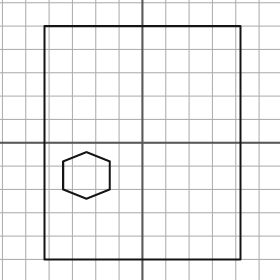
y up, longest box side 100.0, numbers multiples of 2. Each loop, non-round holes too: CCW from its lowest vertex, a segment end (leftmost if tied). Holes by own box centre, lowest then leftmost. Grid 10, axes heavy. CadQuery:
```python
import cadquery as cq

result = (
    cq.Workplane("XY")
    .moveTo(-42.0, -50.0)
    .lineTo(42.0, -50.0)
    .lineTo(42.0, 50.0)
    .lineTo(-42.0, 50.0)
    .close()
    .moveTo(-24.0, -24.0)
    .lineTo(-14.0, -20.0)
    .lineTo(-14.0, -8.0)
    .lineTo(-24.0, -4.0)
    .lineTo(-34.0, -8.0)
    .lineTo(-34.0, -20.0)
    .close()
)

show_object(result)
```